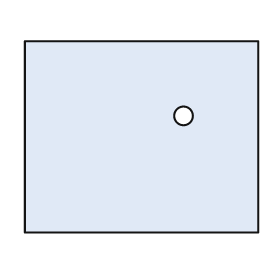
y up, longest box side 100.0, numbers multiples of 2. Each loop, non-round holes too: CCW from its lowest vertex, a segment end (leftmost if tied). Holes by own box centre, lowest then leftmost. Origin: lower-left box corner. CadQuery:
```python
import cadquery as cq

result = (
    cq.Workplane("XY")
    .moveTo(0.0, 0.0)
    .lineTo(100.0, 0.0)
    .lineTo(100.0, 82.0)
    .lineTo(0.0, 82.0)
    .close()
    .moveTo(68.0, 50.0)
    .circle(4.0)
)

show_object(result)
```